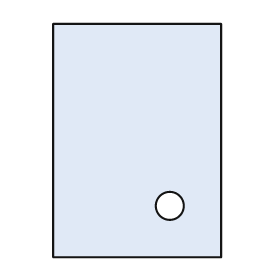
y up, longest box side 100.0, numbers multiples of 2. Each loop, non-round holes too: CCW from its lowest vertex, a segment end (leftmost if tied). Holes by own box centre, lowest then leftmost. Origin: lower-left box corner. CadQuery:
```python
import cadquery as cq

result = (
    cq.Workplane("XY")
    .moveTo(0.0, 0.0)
    .lineTo(72.0, 0.0)
    .lineTo(72.0, 100.0)
    .lineTo(0.0, 100.0)
    .close()
    .moveTo(50.0, 22.0)
    .circle(6.0)
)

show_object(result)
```